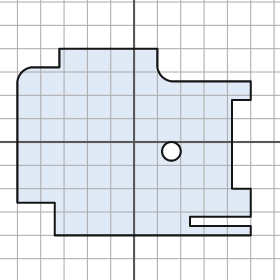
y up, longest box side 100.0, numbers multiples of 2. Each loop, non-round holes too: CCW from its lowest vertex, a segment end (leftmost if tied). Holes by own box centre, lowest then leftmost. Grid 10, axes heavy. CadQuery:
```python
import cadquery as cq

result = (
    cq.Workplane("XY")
    .moveTo(-34.0, -40.0)
    .lineTo(50.0, -40.0)
    .lineTo(50.0, -36.0)
    .lineTo(24.0, -36.0)
    .lineTo(24.0, -32.0)
    .lineTo(50.0, -32.0)
    .lineTo(50.0, -20.0)
    .lineTo(42.0, -20.0)
    .lineTo(42.0, 18.0)
    .lineTo(50.0, 18.0)
    .lineTo(50.0, 26.0)
    .lineTo(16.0, 26.0)
    .threePointArc((12.0, 28.0), (10.0, 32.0))
    .lineTo(10.0, 40.0)
    .lineTo(-32.0, 40.0)
    .lineTo(-32.0, 32.0)
    .lineTo(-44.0, 32.0)
    .threePointArc((-48.0, 30.0), (-50.0, 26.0))
    .lineTo(-50.0, -26.0)
    .lineTo(-34.0, -26.0)
    .close()
    .moveTo(16.0, -4.0)
    .circle(4.0)
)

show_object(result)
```